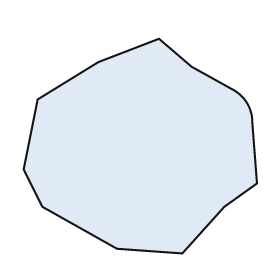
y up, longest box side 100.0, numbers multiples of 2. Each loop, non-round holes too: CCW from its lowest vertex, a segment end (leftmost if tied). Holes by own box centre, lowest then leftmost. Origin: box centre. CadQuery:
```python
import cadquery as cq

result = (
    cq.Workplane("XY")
    .moveTo(18.0, -46.0)
    .lineTo(36.0, -26.0)
    .lineTo(50.0, -16.0)
    .lineTo(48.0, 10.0)
    .threePointArc((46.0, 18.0), (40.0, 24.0))
    .lineTo(22.0, 34.0)
    .lineTo(8.0, 46.0)
    .lineTo(-18.0, 36.0)
    .lineTo(-44.0, 20.0)
    .lineTo(-50.0, -10.0)
    .lineTo(-42.0, -26.0)
    .lineTo(-10.0, -44.0)
    .close()
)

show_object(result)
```